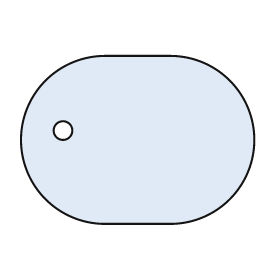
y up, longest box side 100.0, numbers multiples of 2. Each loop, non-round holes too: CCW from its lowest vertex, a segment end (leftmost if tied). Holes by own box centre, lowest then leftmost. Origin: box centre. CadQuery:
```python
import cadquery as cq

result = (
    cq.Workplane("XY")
    .moveTo(-14.0, -36.0)
    .lineTo(14.0, -36.0)
    .threePointArc((50.0, 0.0), (14.0, 36.0))
    .lineTo(-14.0, 36.0)
    .threePointArc((-50.0, 0.0), (-14.0, -36.0))
    .close()
    .moveTo(-32.0, 4.0)
    .circle(4.0)
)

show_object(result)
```